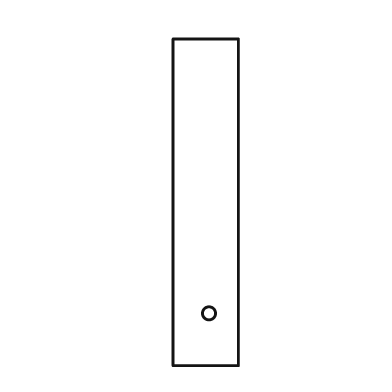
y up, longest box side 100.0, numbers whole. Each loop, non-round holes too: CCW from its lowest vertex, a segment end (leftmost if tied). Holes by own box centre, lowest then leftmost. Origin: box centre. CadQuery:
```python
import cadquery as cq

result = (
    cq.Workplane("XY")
    .moveTo(-10.0, -50.0)
    .lineTo(10.0, -50.0)
    .lineTo(10.0, 50.0)
    .lineTo(-10.0, 50.0)
    .close()
    .moveTo(1.0, -34.0)
    .circle(2.0)
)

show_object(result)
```